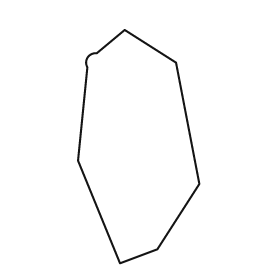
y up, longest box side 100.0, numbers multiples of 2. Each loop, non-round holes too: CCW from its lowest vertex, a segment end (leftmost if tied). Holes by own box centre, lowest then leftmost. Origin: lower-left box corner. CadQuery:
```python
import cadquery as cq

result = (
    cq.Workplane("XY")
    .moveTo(18.0, 0.0)
    .lineTo(34.0, 6.0)
    .lineTo(52.0, 34.0)
    .lineTo(42.0, 86.0)
    .lineTo(20.0, 100.0)
    .lineTo(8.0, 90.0)
    .threePointArc((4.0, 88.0), (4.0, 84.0))
    .lineTo(0.0, 44.0)
    .close()
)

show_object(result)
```